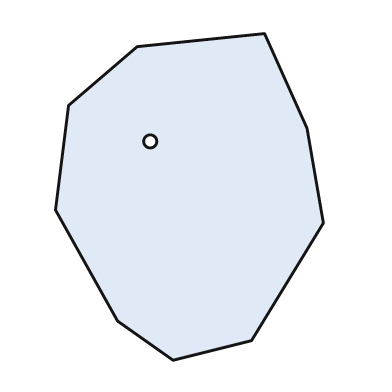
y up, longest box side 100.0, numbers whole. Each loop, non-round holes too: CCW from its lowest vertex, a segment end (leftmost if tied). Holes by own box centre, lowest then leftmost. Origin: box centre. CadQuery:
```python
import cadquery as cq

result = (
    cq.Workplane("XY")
    .moveTo(-5.0, -50.0)
    .lineTo(19.0, -44.0)
    .lineTo(41.0, -8.0)
    .lineTo(36.0, 21.0)
    .lineTo(23.0, 50.0)
    .lineTo(-16.0, 46.0)
    .lineTo(-37.0, 28.0)
    .lineTo(-41.0, -4.0)
    .lineTo(-22.0, -38.0)
    .close()
    .moveTo(-12.0, 17.0)
    .circle(2.0)
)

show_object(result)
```